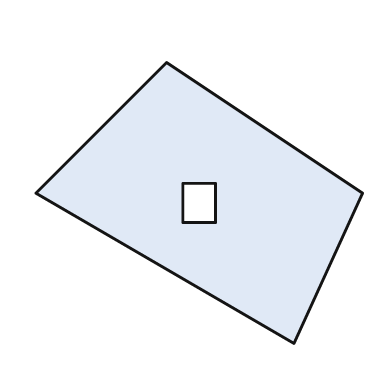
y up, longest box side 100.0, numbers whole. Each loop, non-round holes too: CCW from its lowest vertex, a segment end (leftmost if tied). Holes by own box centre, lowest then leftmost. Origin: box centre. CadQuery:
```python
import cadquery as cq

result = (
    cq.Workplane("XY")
    .moveTo(29.0, -43.0)
    .lineTo(50.0, 3.0)
    .lineTo(-10.0, 43.0)
    .lineTo(-50.0, 3.0)
    .close()
    .moveTo(-5.0, -6.0)
    .lineTo(5.0, -6.0)
    .lineTo(5.0, 6.0)
    .lineTo(-5.0, 6.0)
    .close()
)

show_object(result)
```